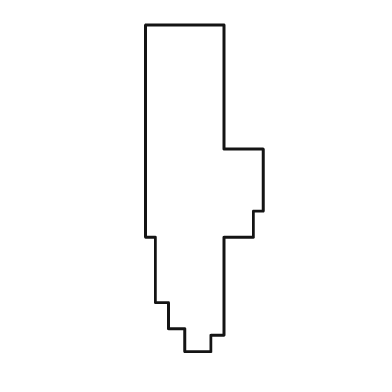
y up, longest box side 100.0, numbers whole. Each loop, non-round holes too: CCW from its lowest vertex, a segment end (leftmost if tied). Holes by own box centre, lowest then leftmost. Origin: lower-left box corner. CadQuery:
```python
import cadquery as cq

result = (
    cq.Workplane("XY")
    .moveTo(12.0, 0.0)
    .lineTo(20.0, 0.0)
    .lineTo(20.0, 5.0)
    .lineTo(24.0, 5.0)
    .lineTo(24.0, 35.0)
    .lineTo(33.0, 35.0)
    .lineTo(33.0, 43.0)
    .lineTo(36.0, 43.0)
    .lineTo(36.0, 62.0)
    .lineTo(24.0, 62.0)
    .lineTo(24.0, 100.0)
    .lineTo(0.0, 100.0)
    .lineTo(0.0, 35.0)
    .lineTo(3.0, 35.0)
    .lineTo(3.0, 15.0)
    .lineTo(7.0, 15.0)
    .lineTo(7.0, 7.0)
    .lineTo(12.0, 7.0)
    .close()
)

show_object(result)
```